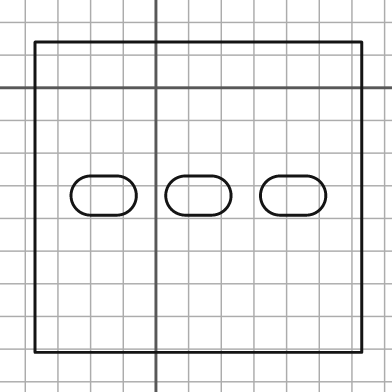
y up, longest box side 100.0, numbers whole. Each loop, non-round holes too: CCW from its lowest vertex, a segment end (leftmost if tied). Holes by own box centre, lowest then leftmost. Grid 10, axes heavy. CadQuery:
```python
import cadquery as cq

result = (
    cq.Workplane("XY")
    .moveTo(-37.0, -81.0)
    .lineTo(63.0, -81.0)
    .lineTo(63.0, 14.0)
    .lineTo(-37.0, 14.0)
    .close()
    .moveTo(-20.0, -39.0)
    .lineTo(-12.0, -39.0)
    .threePointArc((-6.0, -33.0), (-12.0, -27.0))
    .lineTo(-20.0, -27.0)
    .threePointArc((-26.0, -33.0), (-20.0, -39.0))
    .close()
    .moveTo(9.0, -39.0)
    .lineTo(17.0, -39.0)
    .threePointArc((23.0, -33.0), (17.0, -27.0))
    .lineTo(9.0, -27.0)
    .threePointArc((3.0, -33.0), (9.0, -39.0))
    .close()
    .moveTo(38.0, -39.0)
    .lineTo(46.0, -39.0)
    .threePointArc((52.0, -33.0), (46.0, -27.0))
    .lineTo(38.0, -27.0)
    .threePointArc((32.0, -33.0), (38.0, -39.0))
    .close()
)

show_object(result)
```